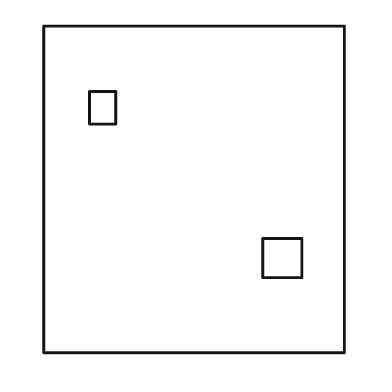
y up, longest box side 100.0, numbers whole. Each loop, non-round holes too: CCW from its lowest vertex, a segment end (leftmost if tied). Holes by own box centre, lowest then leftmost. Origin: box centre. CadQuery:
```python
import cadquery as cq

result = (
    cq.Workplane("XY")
    .moveTo(-46.0, -50.0)
    .lineTo(46.0, -50.0)
    .lineTo(46.0, 50.0)
    .lineTo(-46.0, 50.0)
    .close()
    .moveTo(21.0, -27.0)
    .lineTo(33.0, -27.0)
    .lineTo(33.0, -15.0)
    .lineTo(21.0, -15.0)
    .close()
    .moveTo(-32.0, 20.0)
    .lineTo(-24.0, 20.0)
    .lineTo(-24.0, 30.0)
    .lineTo(-32.0, 30.0)
    .close()
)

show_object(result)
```